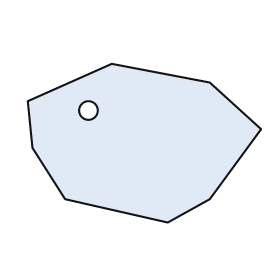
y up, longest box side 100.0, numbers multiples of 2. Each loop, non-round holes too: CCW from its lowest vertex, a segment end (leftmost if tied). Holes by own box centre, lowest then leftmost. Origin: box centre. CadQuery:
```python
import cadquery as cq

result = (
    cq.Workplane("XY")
    .moveTo(10.0, -34.0)
    .lineTo(28.0, -24.0)
    .lineTo(50.0, 6.0)
    .lineTo(28.0, 26.0)
    .lineTo(-14.0, 34.0)
    .lineTo(-50.0, 18.0)
    .lineTo(-48.0, -2.0)
    .lineTo(-34.0, -24.0)
    .close()
    .moveTo(-24.0, 14.0)
    .circle(4.0)
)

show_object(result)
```